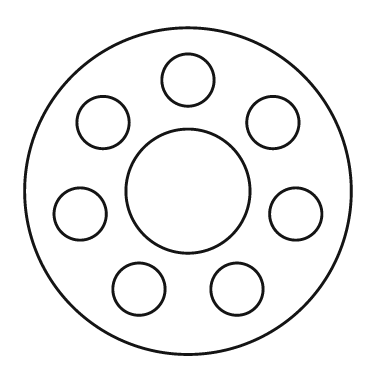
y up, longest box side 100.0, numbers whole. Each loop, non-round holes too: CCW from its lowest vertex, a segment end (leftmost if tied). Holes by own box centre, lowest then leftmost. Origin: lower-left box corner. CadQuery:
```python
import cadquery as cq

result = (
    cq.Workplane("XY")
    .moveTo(50.0, 50.0)
    .circle(50.0)
    .moveTo(35.0, 20.0)
    .circle(8.0)
    .moveTo(65.0, 20.0)
    .circle(8.0)
    .moveTo(17.0, 43.0)
    .circle(8.0)
    .moveTo(83.0, 43.0)
    .circle(8.0)
    .moveTo(50.0, 50.0)
    .circle(19.0)
    .moveTo(24.0, 71.0)
    .circle(8.0)
    .moveTo(76.0, 71.0)
    .circle(8.0)
    .moveTo(50.0, 84.0)
    .circle(8.0)
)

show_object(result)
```